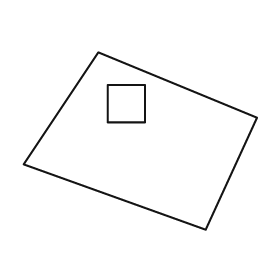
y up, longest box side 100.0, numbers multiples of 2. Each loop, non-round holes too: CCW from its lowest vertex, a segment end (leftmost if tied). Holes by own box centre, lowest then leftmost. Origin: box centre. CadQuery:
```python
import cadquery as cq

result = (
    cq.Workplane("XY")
    .moveTo(28.0, -38.0)
    .lineTo(50.0, 10.0)
    .lineTo(-18.0, 38.0)
    .lineTo(-50.0, -10.0)
    .close()
    .moveTo(-14.0, 8.0)
    .lineTo(2.0, 8.0)
    .lineTo(2.0, 24.0)
    .lineTo(-14.0, 24.0)
    .close()
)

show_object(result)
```